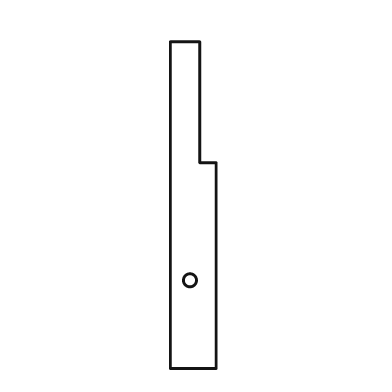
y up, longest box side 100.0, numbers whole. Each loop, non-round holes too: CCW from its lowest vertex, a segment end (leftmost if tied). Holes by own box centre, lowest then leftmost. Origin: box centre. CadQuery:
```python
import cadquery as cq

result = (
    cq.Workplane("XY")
    .moveTo(-7.0, -50.0)
    .lineTo(7.0, -50.0)
    .lineTo(7.0, 13.0)
    .lineTo(2.0, 13.0)
    .lineTo(2.0, 50.0)
    .lineTo(-7.0, 50.0)
    .close()
    .moveTo(-1.0, -23.0)
    .circle(2.0)
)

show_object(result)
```